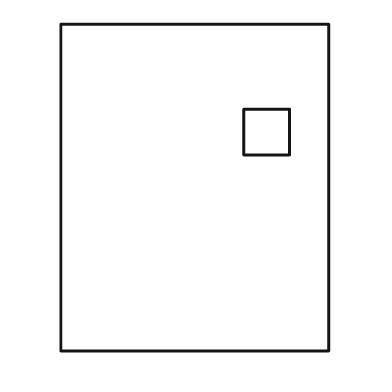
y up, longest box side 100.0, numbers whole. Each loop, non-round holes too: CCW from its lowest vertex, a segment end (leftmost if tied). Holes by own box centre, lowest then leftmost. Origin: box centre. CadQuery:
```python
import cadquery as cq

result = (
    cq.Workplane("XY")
    .moveTo(-41.0, -50.0)
    .lineTo(41.0, -50.0)
    .lineTo(41.0, 50.0)
    .lineTo(-41.0, 50.0)
    .close()
    .moveTo(15.0, 10.0)
    .lineTo(29.0, 10.0)
    .lineTo(29.0, 24.0)
    .lineTo(15.0, 24.0)
    .close()
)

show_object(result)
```